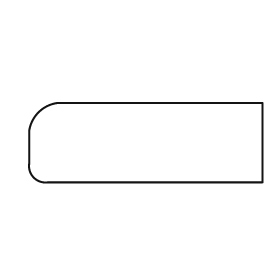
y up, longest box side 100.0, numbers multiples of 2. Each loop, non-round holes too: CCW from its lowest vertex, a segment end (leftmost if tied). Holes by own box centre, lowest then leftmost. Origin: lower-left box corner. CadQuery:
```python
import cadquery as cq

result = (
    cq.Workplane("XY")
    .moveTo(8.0, 0.0)
    .lineTo(100.0, 0.0)
    .lineTo(100.0, 34.0)
    .lineTo(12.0, 34.0)
    .threePointArc((4.0, 30.0), (0.0, 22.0))
    .lineTo(0.0, 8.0)
    .threePointArc((2.0, 2.0), (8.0, 0.0))
    .close()
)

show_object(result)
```